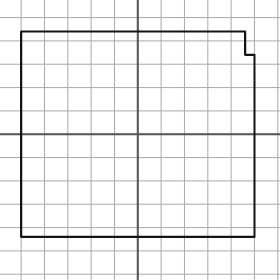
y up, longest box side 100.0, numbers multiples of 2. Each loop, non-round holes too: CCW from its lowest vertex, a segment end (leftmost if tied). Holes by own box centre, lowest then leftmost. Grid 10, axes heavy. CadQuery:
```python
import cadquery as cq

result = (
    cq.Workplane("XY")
    .moveTo(-50.0, -44.0)
    .lineTo(50.0, -44.0)
    .lineTo(50.0, 34.0)
    .lineTo(46.0, 34.0)
    .lineTo(46.0, 44.0)
    .lineTo(-50.0, 44.0)
    .close()
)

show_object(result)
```